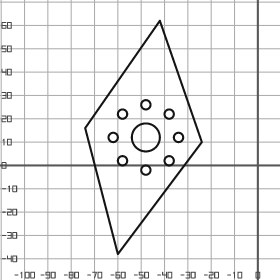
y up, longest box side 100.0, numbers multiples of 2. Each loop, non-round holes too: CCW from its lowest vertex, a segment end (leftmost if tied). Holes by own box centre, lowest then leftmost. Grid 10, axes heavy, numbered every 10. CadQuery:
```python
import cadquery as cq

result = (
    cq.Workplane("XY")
    .moveTo(-60.0, -38.0)
    .lineTo(-24.0, 10.0)
    .lineTo(-42.0, 62.0)
    .lineTo(-74.0, 16.0)
    .close()
    .moveTo(-48.0, -2.0)
    .circle(2.0)
    .moveTo(-58.0, 2.0)
    .circle(2.0)
    .moveTo(-38.0, 2.0)
    .circle(2.0)
    .moveTo(-62.0, 12.0)
    .circle(2.0)
    .moveTo(-48.0, 12.0)
    .circle(6.0)
    .moveTo(-34.0, 12.0)
    .circle(2.0)
    .moveTo(-58.0, 22.0)
    .circle(2.0)
    .moveTo(-38.0, 22.0)
    .circle(2.0)
    .moveTo(-48.0, 26.0)
    .circle(2.0)
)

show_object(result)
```